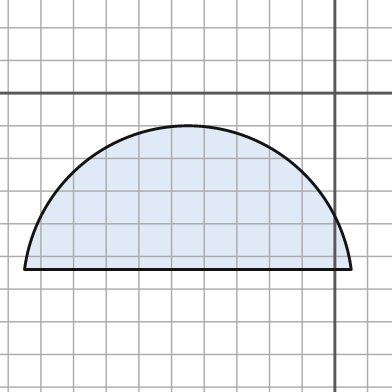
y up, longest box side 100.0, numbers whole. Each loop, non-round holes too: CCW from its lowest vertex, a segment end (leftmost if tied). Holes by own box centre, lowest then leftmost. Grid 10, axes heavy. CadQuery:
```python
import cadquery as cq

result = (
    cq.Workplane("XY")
    .moveTo(-95.0, -54.0)
    .lineTo(5.0, -54.0)
    .threePointArc((-45.0, -10.0), (-95.0, -54.0))
    .close()
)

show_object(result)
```